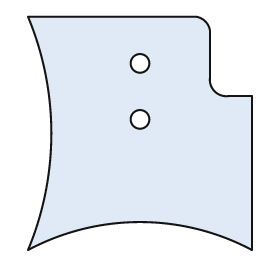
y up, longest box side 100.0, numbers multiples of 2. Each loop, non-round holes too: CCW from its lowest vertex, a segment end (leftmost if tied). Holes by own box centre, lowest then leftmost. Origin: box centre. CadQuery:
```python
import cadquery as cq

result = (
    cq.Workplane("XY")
    .moveTo(-48.0, -50.0)
    .threePointArc((0.0, -38.0), (48.0, -50.0))
    .lineTo(48.0, 16.0)
    .lineTo(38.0, 16.0)
    .threePointArc((32.0, 18.0), (30.0, 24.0))
    .lineTo(30.0, 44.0)
    .threePointArc((28.0, 48.0), (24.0, 50.0))
    .lineTo(-48.0, 50.0)
    .threePointArc((-38.0, 0.0), (-48.0, -50.0))
    .close()
    .moveTo(0.0, 6.0)
    .circle(4.0)
    .moveTo(0.0, 30.0)
    .circle(4.0)
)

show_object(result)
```